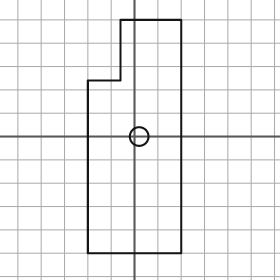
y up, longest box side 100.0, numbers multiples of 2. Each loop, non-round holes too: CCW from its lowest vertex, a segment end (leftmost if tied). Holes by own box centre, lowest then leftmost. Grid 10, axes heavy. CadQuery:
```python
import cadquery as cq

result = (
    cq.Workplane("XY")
    .moveTo(-20.0, -50.0)
    .lineTo(20.0, -50.0)
    .lineTo(20.0, 50.0)
    .lineTo(-6.0, 50.0)
    .lineTo(-6.0, 24.0)
    .lineTo(-20.0, 24.0)
    .close()
    .moveTo(2.0, 0.0)
    .circle(4.0)
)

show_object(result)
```